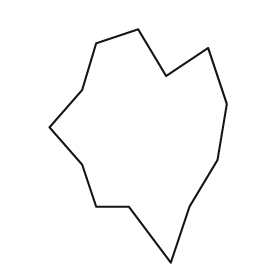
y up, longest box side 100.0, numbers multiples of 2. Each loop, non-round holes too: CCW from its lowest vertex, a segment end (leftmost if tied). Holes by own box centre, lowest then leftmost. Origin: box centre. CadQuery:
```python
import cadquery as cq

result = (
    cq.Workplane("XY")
    .moveTo(14.0, -50.0)
    .lineTo(22.0, -26.0)
    .lineTo(34.0, -6.0)
    .lineTo(38.0, 18.0)
    .lineTo(30.0, 42.0)
    .lineTo(12.0, 30.0)
    .lineTo(0.0, 50.0)
    .lineTo(-18.0, 44.0)
    .lineTo(-24.0, 24.0)
    .lineTo(-38.0, 8.0)
    .lineTo(-24.0, -8.0)
    .lineTo(-18.0, -26.0)
    .lineTo(-4.0, -26.0)
    .close()
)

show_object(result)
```